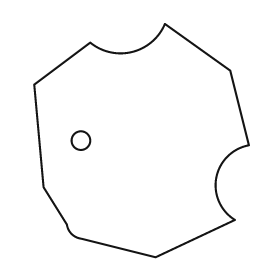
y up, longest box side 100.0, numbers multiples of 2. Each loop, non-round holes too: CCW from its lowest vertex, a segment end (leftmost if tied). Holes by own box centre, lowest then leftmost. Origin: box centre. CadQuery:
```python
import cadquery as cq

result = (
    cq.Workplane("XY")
    .moveTo(6.0, -50.0)
    .lineTo(40.0, -34.0)
    .threePointArc((32.0, -16.0), (46.0, -2.0))
    .lineTo(38.0, 30.0)
    .lineTo(10.0, 50.0)
    .threePointArc((-4.0, 38.0), (-22.0, 42.0))
    .lineTo(-46.0, 24.0)
    .lineTo(-42.0, -20.0)
    .lineTo(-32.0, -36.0)
    .threePointArc((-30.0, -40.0), (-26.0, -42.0))
    .close()
    .moveTo(-26.0, 0.0)
    .circle(4.0)
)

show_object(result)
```